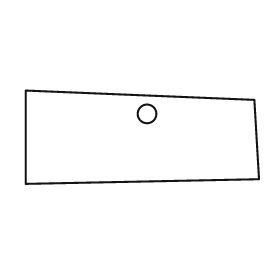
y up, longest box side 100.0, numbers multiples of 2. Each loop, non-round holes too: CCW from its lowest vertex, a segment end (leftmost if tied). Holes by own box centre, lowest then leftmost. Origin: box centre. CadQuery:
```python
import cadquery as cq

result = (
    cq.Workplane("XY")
    .moveTo(-50.0, -20.0)
    .lineTo(50.0, -18.0)
    .lineTo(48.0, 16.0)
    .lineTo(-50.0, 20.0)
    .close()
    .moveTo(2.0, 10.0)
    .circle(4.0)
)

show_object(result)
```